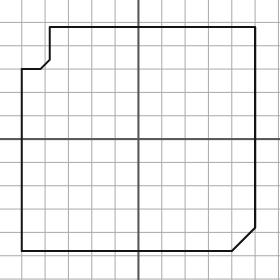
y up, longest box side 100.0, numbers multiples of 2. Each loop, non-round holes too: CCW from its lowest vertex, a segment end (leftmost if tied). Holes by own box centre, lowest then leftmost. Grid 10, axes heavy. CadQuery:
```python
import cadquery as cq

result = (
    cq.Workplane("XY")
    .moveTo(-50.0, -48.0)
    .lineTo(40.0, -48.0)
    .lineTo(50.0, -38.0)
    .lineTo(50.0, 48.0)
    .lineTo(-38.0, 48.0)
    .lineTo(-38.0, 34.0)
    .lineTo(-42.0, 30.0)
    .lineTo(-50.0, 30.0)
    .close()
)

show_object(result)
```